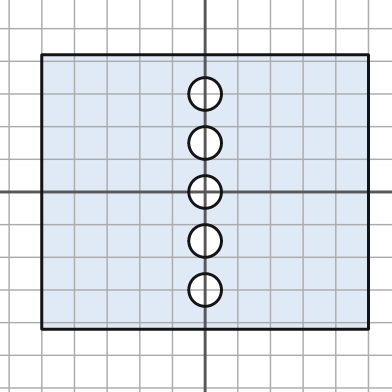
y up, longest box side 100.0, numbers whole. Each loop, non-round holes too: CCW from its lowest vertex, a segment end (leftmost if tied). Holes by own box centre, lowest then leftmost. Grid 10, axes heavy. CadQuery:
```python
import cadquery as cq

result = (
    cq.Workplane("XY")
    .moveTo(-50.0, -42.0)
    .lineTo(50.0, -42.0)
    .lineTo(50.0, 42.0)
    .lineTo(-50.0, 42.0)
    .close()
    .moveTo(0.0, -30.0)
    .circle(5.0)
    .moveTo(0.0, -15.0)
    .circle(5.0)
    .moveTo(0.0, 0.0)
    .circle(5.0)
    .moveTo(0.0, 15.0)
    .circle(5.0)
    .moveTo(0.0, 30.0)
    .circle(5.0)
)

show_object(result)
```